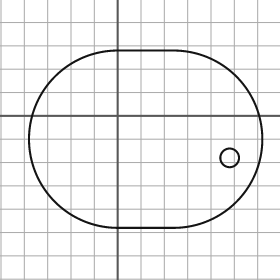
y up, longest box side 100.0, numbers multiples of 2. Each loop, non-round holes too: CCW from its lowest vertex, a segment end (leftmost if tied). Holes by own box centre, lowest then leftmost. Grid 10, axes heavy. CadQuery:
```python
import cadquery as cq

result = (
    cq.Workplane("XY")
    .moveTo(0.0, -48.0)
    .lineTo(24.0, -48.0)
    .threePointArc((62.0, -10.0), (24.0, 28.0))
    .lineTo(0.0, 28.0)
    .threePointArc((-38.0, -10.0), (0.0, -48.0))
    .close()
    .moveTo(48.0, -18.0)
    .circle(4.0)
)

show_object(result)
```